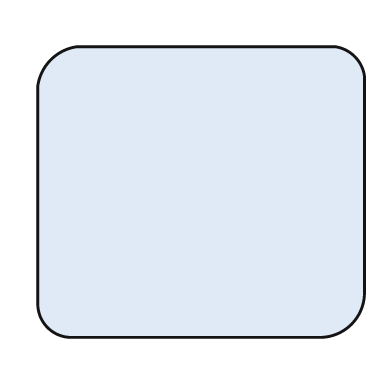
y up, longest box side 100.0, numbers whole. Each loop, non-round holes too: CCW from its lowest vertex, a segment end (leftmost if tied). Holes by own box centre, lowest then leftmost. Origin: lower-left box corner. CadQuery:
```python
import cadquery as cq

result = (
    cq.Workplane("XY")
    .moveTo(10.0, 0.0)
    .lineTo(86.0, 0.0)
    .threePointArc((96.0, 4.0), (100.0, 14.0))
    .lineTo(100.0, 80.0)
    .threePointArc((97.0, 86.0), (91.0, 89.0))
    .lineTo(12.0, 89.0)
    .threePointArc((4.0, 85.0), (0.0, 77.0))
    .lineTo(0.0, 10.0)
    .threePointArc((3.0, 3.0), (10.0, 0.0))
    .close()
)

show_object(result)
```